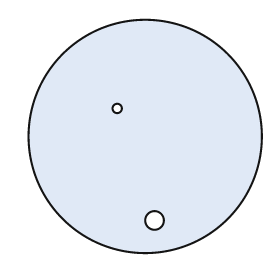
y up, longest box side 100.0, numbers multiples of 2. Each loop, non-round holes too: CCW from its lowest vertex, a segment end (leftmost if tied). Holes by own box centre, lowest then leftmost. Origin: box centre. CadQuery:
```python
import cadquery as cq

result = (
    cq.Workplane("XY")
    .moveTo(0.0, 0.0)
    .circle(50.0)
    .moveTo(4.0, -36.0)
    .circle(4.0)
    .moveTo(-12.0, 12.0)
    .circle(2.0)
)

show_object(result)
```